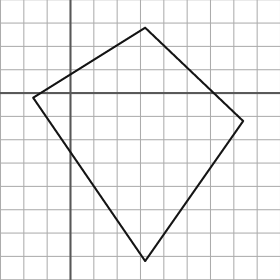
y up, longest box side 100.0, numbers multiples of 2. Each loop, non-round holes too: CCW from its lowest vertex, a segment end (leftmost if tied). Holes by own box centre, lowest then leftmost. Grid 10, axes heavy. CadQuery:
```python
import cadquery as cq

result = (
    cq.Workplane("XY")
    .moveTo(32.0, -72.0)
    .lineTo(74.0, -12.0)
    .lineTo(32.0, 28.0)
    .lineTo(-16.0, -2.0)
    .close()
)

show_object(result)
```